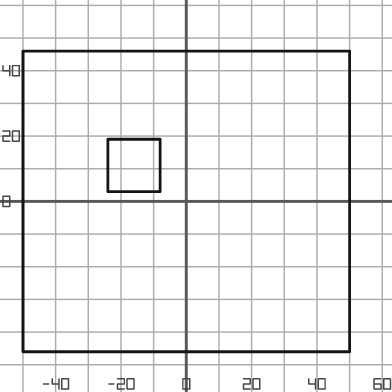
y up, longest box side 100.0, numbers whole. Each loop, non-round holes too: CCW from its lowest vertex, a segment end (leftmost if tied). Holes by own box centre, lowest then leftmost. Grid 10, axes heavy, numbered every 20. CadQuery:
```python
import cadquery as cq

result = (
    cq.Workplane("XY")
    .moveTo(-50.0, -46.0)
    .lineTo(50.0, -46.0)
    .lineTo(50.0, 46.0)
    .lineTo(-50.0, 46.0)
    .close()
    .moveTo(-24.0, 3.0)
    .lineTo(-8.0, 3.0)
    .lineTo(-8.0, 19.0)
    .lineTo(-24.0, 19.0)
    .close()
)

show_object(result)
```